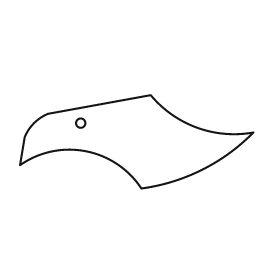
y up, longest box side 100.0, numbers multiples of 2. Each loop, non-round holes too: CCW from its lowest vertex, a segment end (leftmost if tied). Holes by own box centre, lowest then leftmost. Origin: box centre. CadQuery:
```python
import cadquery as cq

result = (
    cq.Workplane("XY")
    .moveTo(2.0, -20.0)
    .threePointArc((28.0, -12.0), (50.0, 4.0))
    .threePointArc((26.0, 6.0), (6.0, 20.0))
    .lineTo(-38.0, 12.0)
    .threePointArc((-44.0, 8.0), (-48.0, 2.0))
    .lineTo(-50.0, -10.0)
    .threePointArc((-22.0, -4.0), (2.0, -20.0))
    .close()
    .moveTo(-24.0, 8.0)
    .circle(2.0)
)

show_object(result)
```